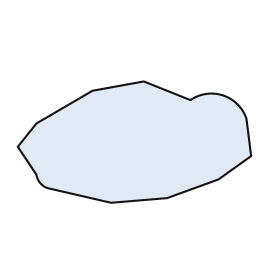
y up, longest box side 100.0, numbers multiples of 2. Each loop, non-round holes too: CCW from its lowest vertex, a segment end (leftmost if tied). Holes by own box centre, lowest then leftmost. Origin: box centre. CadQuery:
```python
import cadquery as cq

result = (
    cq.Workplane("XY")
    .moveTo(-10.0, -26.0)
    .lineTo(14.0, -24.0)
    .lineTo(36.0, -16.0)
    .lineTo(50.0, -6.0)
    .lineTo(48.0, 10.0)
    .threePointArc((38.0, 20.0), (24.0, 18.0))
    .lineTo(4.0, 26.0)
    .lineTo(-18.0, 22.0)
    .lineTo(-42.0, 8.0)
    .lineTo(-50.0, -2.0)
    .lineTo(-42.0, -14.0)
    .threePointArc((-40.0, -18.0), (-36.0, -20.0))
    .close()
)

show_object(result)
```